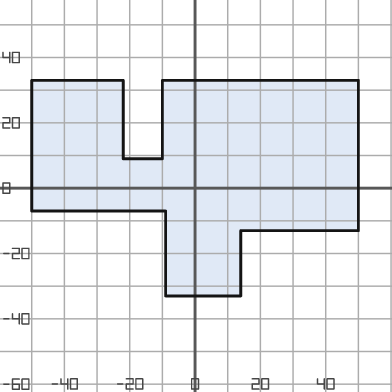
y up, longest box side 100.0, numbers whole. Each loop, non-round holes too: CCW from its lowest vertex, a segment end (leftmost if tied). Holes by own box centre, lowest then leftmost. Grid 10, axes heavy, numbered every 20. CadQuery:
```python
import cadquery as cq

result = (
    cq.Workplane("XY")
    .moveTo(-9.0, -33.0)
    .lineTo(14.0, -33.0)
    .lineTo(14.0, -13.0)
    .lineTo(50.0, -13.0)
    .lineTo(50.0, 33.0)
    .lineTo(-10.0, 33.0)
    .lineTo(-10.0, 9.0)
    .lineTo(-22.0, 9.0)
    .lineTo(-22.0, 33.0)
    .lineTo(-50.0, 33.0)
    .lineTo(-50.0, -7.0)
    .lineTo(-9.0, -7.0)
    .close()
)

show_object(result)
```